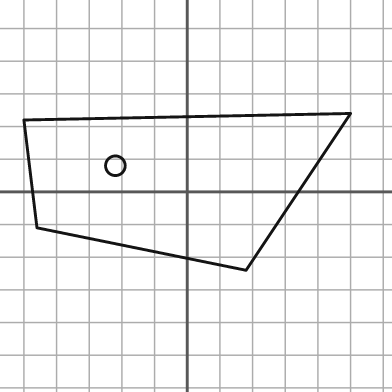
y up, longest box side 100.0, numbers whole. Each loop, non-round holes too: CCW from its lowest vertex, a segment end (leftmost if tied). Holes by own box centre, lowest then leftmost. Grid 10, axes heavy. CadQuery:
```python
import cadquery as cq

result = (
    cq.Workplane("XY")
    .moveTo(18.0, -24.0)
    .lineTo(50.0, 24.0)
    .lineTo(-50.0, 22.0)
    .lineTo(-46.0, -11.0)
    .close()
    .moveTo(-22.0, 8.0)
    .circle(3.0)
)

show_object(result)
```